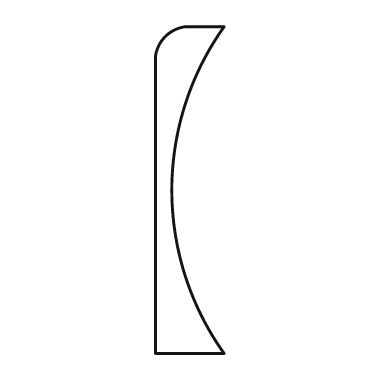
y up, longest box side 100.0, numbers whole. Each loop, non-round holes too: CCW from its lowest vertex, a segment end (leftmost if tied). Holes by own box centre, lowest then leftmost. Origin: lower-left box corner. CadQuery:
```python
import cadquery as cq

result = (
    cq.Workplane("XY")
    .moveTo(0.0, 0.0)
    .lineTo(21.0, 0.0)
    .threePointArc((5.0, 50.0), (21.0, 100.0))
    .lineTo(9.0, 100.0)
    .threePointArc((3.0, 97.0), (0.0, 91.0))
    .close()
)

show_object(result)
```